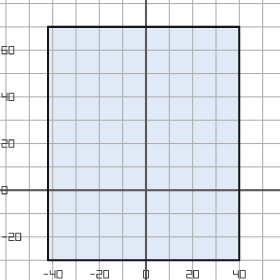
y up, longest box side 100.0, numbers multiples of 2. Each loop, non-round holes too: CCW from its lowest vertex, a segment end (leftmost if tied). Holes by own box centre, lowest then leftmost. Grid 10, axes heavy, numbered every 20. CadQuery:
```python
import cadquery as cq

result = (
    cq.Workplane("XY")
    .moveTo(-42.0, -30.0)
    .lineTo(40.0, -30.0)
    .lineTo(40.0, 70.0)
    .lineTo(-42.0, 70.0)
    .close()
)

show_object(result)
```